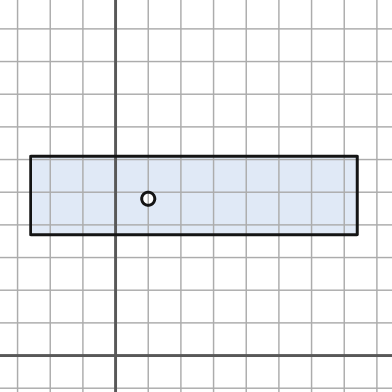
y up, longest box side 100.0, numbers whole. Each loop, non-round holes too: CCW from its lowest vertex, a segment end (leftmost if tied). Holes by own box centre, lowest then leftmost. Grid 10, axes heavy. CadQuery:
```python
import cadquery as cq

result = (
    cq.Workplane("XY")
    .moveTo(-26.0, 37.0)
    .lineTo(74.0, 37.0)
    .lineTo(74.0, 61.0)
    .lineTo(-26.0, 61.0)
    .close()
    .moveTo(10.0, 48.0)
    .circle(2.0)
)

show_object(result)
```